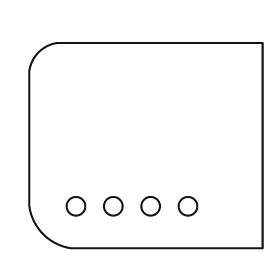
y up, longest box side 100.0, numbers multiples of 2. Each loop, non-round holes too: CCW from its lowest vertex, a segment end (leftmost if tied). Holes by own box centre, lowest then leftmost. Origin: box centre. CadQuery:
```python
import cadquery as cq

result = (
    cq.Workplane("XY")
    .moveTo(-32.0, -44.0)
    .lineTo(50.0, -44.0)
    .lineTo(50.0, 44.0)
    .lineTo(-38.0, 44.0)
    .threePointArc((-46.0, 40.0), (-50.0, 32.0))
    .lineTo(-50.0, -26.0)
    .threePointArc((-44.0, -38.0), (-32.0, -44.0))
    .close()
    .moveTo(-30.0, -26.0)
    .circle(4.0)
    .moveTo(-14.0, -26.0)
    .circle(4.0)
    .moveTo(2.0, -26.0)
    .circle(4.0)
    .moveTo(18.0, -26.0)
    .circle(4.0)
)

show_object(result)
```